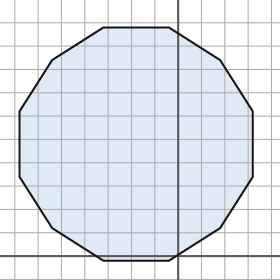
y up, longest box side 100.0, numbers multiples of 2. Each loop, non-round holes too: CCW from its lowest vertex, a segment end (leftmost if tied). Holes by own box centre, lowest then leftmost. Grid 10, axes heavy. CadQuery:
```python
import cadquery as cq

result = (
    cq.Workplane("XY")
    .moveTo(-32.0, -2.0)
    .lineTo(-4.0, -2.0)
    .lineTo(18.0, 12.0)
    .lineTo(32.0, 34.0)
    .lineTo(32.0, 62.0)
    .lineTo(18.0, 84.0)
    .lineTo(-4.0, 98.0)
    .lineTo(-32.0, 98.0)
    .lineTo(-54.0, 84.0)
    .lineTo(-68.0, 62.0)
    .lineTo(-68.0, 34.0)
    .lineTo(-54.0, 12.0)
    .close()
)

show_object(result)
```